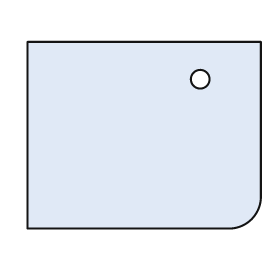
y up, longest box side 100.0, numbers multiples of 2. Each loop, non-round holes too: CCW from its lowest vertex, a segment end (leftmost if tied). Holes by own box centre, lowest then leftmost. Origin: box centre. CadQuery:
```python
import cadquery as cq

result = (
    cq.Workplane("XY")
    .moveTo(-50.0, -40.0)
    .lineTo(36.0, -40.0)
    .threePointArc((46.0, -36.0), (50.0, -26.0))
    .lineTo(50.0, 40.0)
    .lineTo(-50.0, 40.0)
    .close()
    .moveTo(24.0, 24.0)
    .circle(4.0)
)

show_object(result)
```